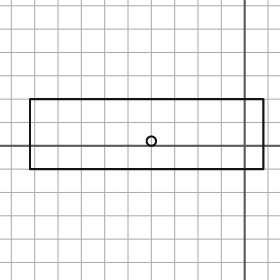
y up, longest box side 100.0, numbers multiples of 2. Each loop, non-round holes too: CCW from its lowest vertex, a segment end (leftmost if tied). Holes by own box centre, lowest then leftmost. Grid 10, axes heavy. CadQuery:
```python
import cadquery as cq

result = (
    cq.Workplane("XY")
    .moveTo(-92.0, -10.0)
    .lineTo(8.0, -10.0)
    .lineTo(8.0, 20.0)
    .lineTo(-92.0, 20.0)
    .close()
    .moveTo(-40.0, 2.0)
    .circle(2.0)
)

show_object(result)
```